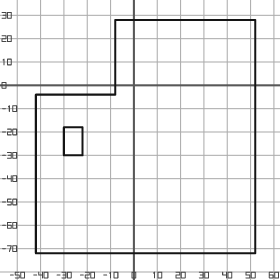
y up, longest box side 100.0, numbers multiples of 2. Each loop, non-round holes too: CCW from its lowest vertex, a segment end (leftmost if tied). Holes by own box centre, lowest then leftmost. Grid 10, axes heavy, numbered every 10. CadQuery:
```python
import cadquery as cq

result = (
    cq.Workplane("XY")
    .moveTo(-42.0, -72.0)
    .lineTo(52.0, -72.0)
    .lineTo(52.0, 28.0)
    .lineTo(-8.0, 28.0)
    .lineTo(-8.0, -4.0)
    .lineTo(-42.0, -4.0)
    .close()
    .moveTo(-30.0, -30.0)
    .lineTo(-22.0, -30.0)
    .lineTo(-22.0, -18.0)
    .lineTo(-30.0, -18.0)
    .close()
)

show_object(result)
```